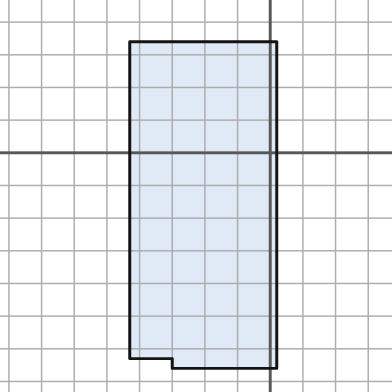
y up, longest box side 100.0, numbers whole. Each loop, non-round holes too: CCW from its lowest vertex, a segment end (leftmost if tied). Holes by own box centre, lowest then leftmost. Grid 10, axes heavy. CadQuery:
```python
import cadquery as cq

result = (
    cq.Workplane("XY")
    .moveTo(-30.0, -66.0)
    .lineTo(2.0, -66.0)
    .lineTo(2.0, 34.0)
    .lineTo(-43.0, 34.0)
    .lineTo(-43.0, -63.0)
    .lineTo(-30.0, -63.0)
    .close()
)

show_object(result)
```